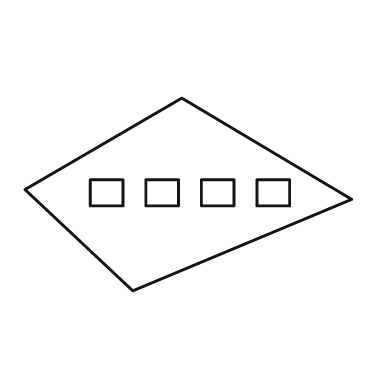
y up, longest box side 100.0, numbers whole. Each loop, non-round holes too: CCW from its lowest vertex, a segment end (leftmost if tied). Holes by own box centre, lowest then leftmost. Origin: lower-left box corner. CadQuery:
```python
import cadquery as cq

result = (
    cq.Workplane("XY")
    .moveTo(33.0, 0.0)
    .lineTo(100.0, 28.0)
    .lineTo(48.0, 59.0)
    .lineTo(0.0, 31.0)
    .close()
    .moveTo(20.0, 26.0)
    .lineTo(30.0, 26.0)
    .lineTo(30.0, 34.0)
    .lineTo(20.0, 34.0)
    .close()
    .moveTo(37.0, 26.0)
    .lineTo(47.0, 26.0)
    .lineTo(47.0, 34.0)
    .lineTo(37.0, 34.0)
    .close()
    .moveTo(54.0, 26.0)
    .lineTo(64.0, 26.0)
    .lineTo(64.0, 34.0)
    .lineTo(54.0, 34.0)
    .close()
    .moveTo(71.0, 26.0)
    .lineTo(81.0, 26.0)
    .lineTo(81.0, 34.0)
    .lineTo(71.0, 34.0)
    .close()
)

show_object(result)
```